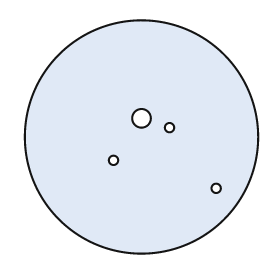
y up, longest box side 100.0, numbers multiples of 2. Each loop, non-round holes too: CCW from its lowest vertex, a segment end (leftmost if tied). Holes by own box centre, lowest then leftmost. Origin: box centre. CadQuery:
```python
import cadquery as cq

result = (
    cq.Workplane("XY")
    .moveTo(0.0, 0.0)
    .circle(50.0)
    .moveTo(32.0, -22.0)
    .circle(2.0)
    .moveTo(-12.0, -10.0)
    .circle(2.0)
    .moveTo(12.0, 4.0)
    .circle(2.0)
    .moveTo(0.0, 8.0)
    .circle(4.0)
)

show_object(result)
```